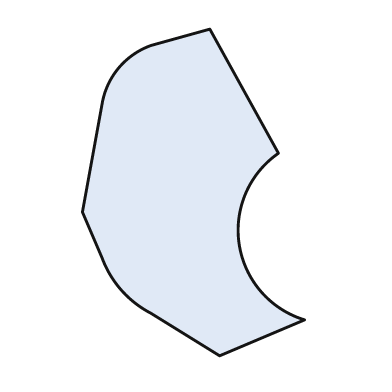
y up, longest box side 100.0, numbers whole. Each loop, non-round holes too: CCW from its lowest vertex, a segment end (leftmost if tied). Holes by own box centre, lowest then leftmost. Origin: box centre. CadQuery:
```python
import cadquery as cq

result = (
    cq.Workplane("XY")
    .moveTo(8.0, -50.0)
    .lineTo(34.0, -39.0)
    .threePointArc((14.0, -16.0), (26.0, 12.0))
    .lineTo(5.0, 50.0)
    .lineTo(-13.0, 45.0)
    .threePointArc((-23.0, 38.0), (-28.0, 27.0))
    .lineTo(-34.0, -6.0)
    .lineTo(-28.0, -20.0)
    .threePointArc((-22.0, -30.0), (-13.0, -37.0))
    .close()
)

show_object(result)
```